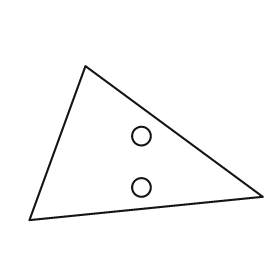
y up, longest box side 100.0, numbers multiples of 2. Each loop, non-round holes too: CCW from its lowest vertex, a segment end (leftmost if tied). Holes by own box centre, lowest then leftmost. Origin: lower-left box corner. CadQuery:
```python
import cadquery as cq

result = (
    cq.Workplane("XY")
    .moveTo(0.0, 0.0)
    .lineTo(100.0, 10.0)
    .lineTo(24.0, 66.0)
    .close()
    .moveTo(48.0, 14.0)
    .circle(4.0)
    .moveTo(48.0, 36.0)
    .circle(4.0)
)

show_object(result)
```